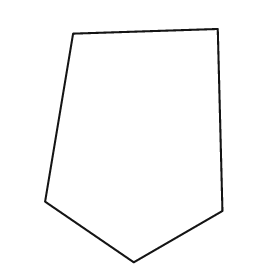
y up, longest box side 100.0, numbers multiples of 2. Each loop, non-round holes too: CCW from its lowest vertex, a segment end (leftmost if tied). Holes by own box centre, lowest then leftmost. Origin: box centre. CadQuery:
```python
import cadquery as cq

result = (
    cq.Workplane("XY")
    .moveTo(0.0, -50.0)
    .lineTo(38.0, -28.0)
    .lineTo(36.0, 50.0)
    .lineTo(-26.0, 48.0)
    .lineTo(-38.0, -24.0)
    .close()
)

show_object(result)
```